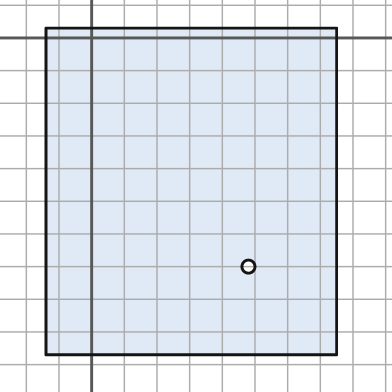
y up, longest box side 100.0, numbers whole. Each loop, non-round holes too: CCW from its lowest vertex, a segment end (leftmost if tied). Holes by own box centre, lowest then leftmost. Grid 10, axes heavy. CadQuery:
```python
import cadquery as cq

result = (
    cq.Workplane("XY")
    .moveTo(-14.0, -97.0)
    .lineTo(75.0, -97.0)
    .lineTo(75.0, 3.0)
    .lineTo(-14.0, 3.0)
    .close()
    .moveTo(48.0, -70.0)
    .circle(2.0)
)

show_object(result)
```